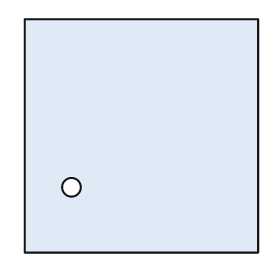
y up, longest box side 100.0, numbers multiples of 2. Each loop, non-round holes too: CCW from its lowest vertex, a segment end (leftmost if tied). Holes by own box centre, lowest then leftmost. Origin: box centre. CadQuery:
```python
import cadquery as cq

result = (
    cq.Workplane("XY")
    .moveTo(-50.0, -50.0)
    .lineTo(50.0, -50.0)
    .lineTo(50.0, 50.0)
    .lineTo(-50.0, 50.0)
    .close()
    .moveTo(-30.0, -22.0)
    .circle(4.0)
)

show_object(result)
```